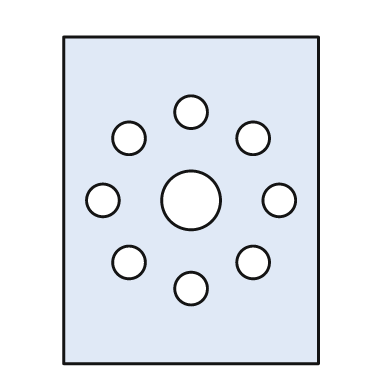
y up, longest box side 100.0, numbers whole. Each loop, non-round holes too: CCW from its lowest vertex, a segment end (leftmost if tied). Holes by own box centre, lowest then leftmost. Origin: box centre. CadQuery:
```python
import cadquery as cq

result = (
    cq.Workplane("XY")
    .moveTo(-39.0, -50.0)
    .lineTo(39.0, -50.0)
    .lineTo(39.0, 50.0)
    .lineTo(-39.0, 50.0)
    .close()
    .moveTo(0.0, -27.0)
    .circle(5.0)
    .moveTo(-19.0, -19.0)
    .circle(5.0)
    .moveTo(19.0, -19.0)
    .circle(5.0)
    .moveTo(-27.0, 0.0)
    .circle(5.0)
    .moveTo(0.0, 0.0)
    .circle(9.0)
    .moveTo(27.0, 0.0)
    .circle(5.0)
    .moveTo(-19.0, 19.0)
    .circle(5.0)
    .moveTo(19.0, 19.0)
    .circle(5.0)
    .moveTo(0.0, 27.0)
    .circle(5.0)
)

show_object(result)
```